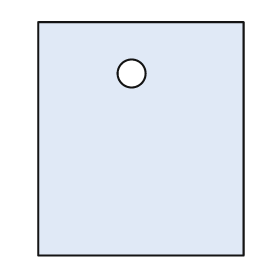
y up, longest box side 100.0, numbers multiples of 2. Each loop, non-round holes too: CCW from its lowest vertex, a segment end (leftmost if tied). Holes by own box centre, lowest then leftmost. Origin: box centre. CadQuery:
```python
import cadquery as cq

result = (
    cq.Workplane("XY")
    .moveTo(-44.0, -50.0)
    .lineTo(44.0, -50.0)
    .lineTo(44.0, 50.0)
    .lineTo(-44.0, 50.0)
    .close()
    .moveTo(-4.0, 28.0)
    .circle(6.0)
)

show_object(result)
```